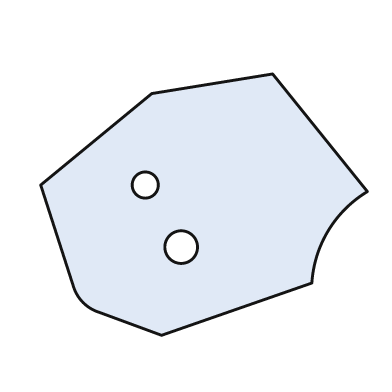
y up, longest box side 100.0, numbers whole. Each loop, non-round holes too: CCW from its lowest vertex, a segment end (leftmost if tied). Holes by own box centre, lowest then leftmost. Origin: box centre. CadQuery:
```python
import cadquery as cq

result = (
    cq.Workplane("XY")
    .moveTo(-13.0, -40.0)
    .lineTo(33.0, -24.0)
    .threePointArc((38.0, -8.0), (50.0, 4.0))
    .lineTo(21.0, 40.0)
    .lineTo(-16.0, 34.0)
    .lineTo(-50.0, 6.0)
    .lineTo(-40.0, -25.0)
    .threePointArc((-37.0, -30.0), (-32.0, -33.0))
    .close()
    .moveTo(-7.0, -13.0)
    .circle(5.0)
    .moveTo(-18.0, 6.0)
    .circle(4.0)
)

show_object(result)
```